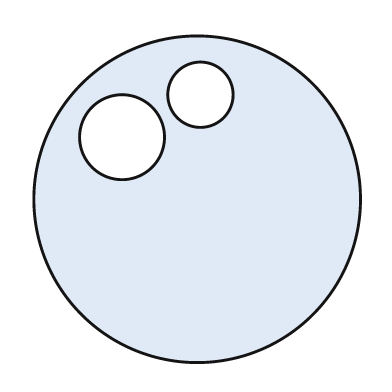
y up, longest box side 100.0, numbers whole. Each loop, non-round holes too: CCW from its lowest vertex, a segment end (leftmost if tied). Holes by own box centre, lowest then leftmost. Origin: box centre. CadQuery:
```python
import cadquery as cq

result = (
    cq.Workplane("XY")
    .moveTo(0.0, 0.0)
    .circle(50.0)
    .moveTo(-23.0, 19.0)
    .circle(13.0)
    .moveTo(1.0, 32.0)
    .circle(10.0)
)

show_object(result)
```